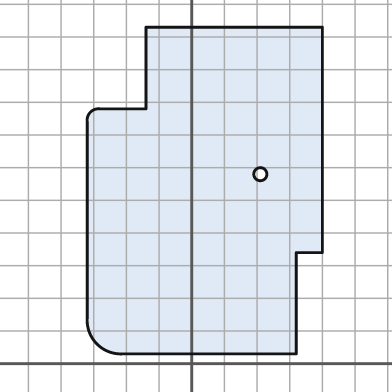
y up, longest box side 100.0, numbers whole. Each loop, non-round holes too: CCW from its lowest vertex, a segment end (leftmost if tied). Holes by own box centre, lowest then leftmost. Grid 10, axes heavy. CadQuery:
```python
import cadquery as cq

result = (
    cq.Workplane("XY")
    .moveTo(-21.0, 3.0)
    .lineTo(32.0, 3.0)
    .lineTo(32.0, 34.0)
    .lineTo(40.0, 34.0)
    .lineTo(40.0, 103.0)
    .lineTo(-14.0, 103.0)
    .lineTo(-14.0, 78.0)
    .lineTo(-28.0, 78.0)
    .threePointArc((-31.0, 77.0), (-32.0, 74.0))
    .lineTo(-32.0, 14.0)
    .threePointArc((-29.0, 6.0), (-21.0, 3.0))
    .close()
    .moveTo(21.0, 58.0)
    .circle(2.0)
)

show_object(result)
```